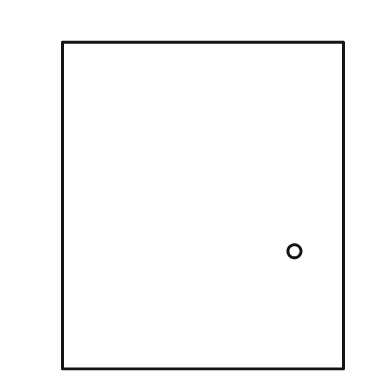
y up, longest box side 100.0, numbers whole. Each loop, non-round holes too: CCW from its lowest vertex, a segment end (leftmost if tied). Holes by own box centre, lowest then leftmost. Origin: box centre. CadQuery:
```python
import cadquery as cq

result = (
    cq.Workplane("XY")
    .moveTo(-43.0, -50.0)
    .lineTo(43.0, -50.0)
    .lineTo(43.0, 50.0)
    .lineTo(-43.0, 50.0)
    .close()
    .moveTo(28.0, -14.0)
    .circle(2.0)
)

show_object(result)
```